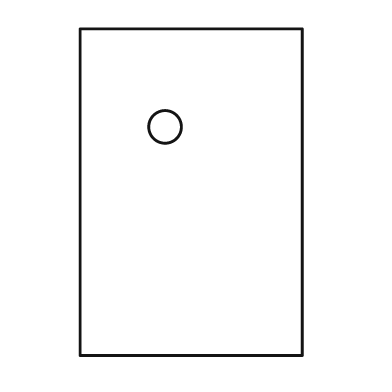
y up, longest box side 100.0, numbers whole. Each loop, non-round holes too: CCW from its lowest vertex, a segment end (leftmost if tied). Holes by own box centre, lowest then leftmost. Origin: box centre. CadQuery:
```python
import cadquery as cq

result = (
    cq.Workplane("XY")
    .moveTo(-34.0, -50.0)
    .lineTo(34.0, -50.0)
    .lineTo(34.0, 50.0)
    .lineTo(-34.0, 50.0)
    .close()
    .moveTo(-8.0, 20.0)
    .circle(5.0)
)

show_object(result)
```